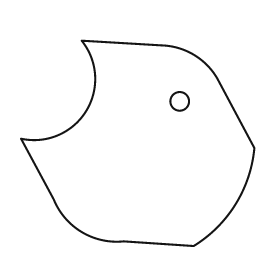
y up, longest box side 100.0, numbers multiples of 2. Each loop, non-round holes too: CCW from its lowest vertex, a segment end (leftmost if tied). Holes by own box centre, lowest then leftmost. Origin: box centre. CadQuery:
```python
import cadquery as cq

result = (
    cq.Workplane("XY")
    .moveTo(24.0, -44.0)
    .threePointArc((42.0, -26.0), (50.0, -2.0))
    .lineTo(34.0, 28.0)
    .threePointArc((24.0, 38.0), (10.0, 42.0))
    .lineTo(-24.0, 44.0)
    .threePointArc((-22.0, 14.0), (-50.0, 2.0))
    .lineTo(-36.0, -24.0)
    .threePointArc((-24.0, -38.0), (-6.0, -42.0))
    .close()
    .moveTo(18.0, 18.0)
    .circle(4.0)
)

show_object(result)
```